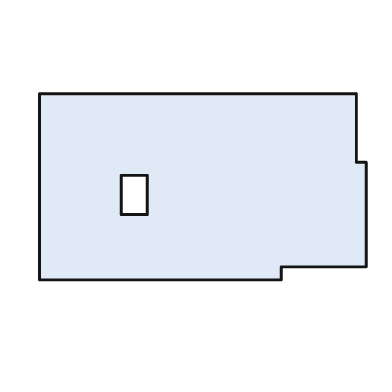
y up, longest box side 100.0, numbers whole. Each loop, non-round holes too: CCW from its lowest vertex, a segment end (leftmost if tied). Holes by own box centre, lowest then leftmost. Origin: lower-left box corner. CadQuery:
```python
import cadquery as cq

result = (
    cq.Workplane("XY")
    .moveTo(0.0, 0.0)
    .lineTo(74.0, 0.0)
    .lineTo(74.0, 4.0)
    .lineTo(100.0, 4.0)
    .lineTo(100.0, 36.0)
    .lineTo(97.0, 36.0)
    .lineTo(97.0, 57.0)
    .lineTo(0.0, 57.0)
    .close()
    .moveTo(25.0, 20.0)
    .lineTo(33.0, 20.0)
    .lineTo(33.0, 32.0)
    .lineTo(25.0, 32.0)
    .close()
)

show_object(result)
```